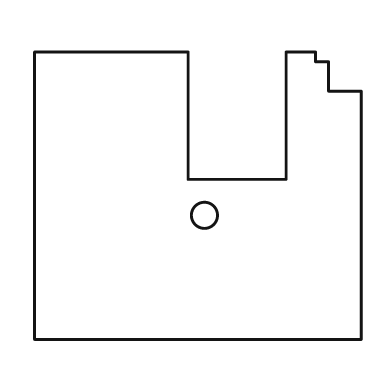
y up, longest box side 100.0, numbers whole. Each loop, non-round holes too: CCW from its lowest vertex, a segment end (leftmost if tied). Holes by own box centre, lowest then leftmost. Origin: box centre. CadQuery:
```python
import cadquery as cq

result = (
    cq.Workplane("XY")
    .moveTo(-50.0, -44.0)
    .lineTo(50.0, -44.0)
    .lineTo(50.0, 32.0)
    .lineTo(40.0, 32.0)
    .lineTo(40.0, 41.0)
    .lineTo(36.0, 41.0)
    .lineTo(36.0, 44.0)
    .lineTo(27.0, 44.0)
    .lineTo(27.0, 5.0)
    .lineTo(-3.0, 5.0)
    .lineTo(-3.0, 44.0)
    .lineTo(-50.0, 44.0)
    .close()
    .moveTo(2.0, -6.0)
    .circle(4.0)
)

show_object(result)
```